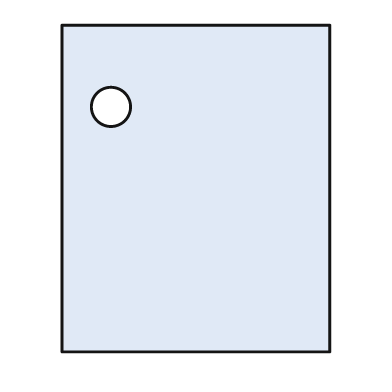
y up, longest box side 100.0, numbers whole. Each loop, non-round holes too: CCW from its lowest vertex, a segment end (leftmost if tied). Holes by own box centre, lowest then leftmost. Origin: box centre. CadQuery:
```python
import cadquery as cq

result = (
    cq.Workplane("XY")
    .moveTo(-41.0, -50.0)
    .lineTo(41.0, -50.0)
    .lineTo(41.0, 50.0)
    .lineTo(-41.0, 50.0)
    .close()
    .moveTo(-26.0, 25.0)
    .circle(6.0)
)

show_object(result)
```